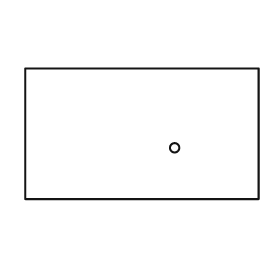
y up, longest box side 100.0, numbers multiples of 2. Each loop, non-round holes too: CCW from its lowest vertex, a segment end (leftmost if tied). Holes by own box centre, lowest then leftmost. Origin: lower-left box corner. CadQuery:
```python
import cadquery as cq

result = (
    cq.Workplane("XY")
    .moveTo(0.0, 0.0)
    .lineTo(100.0, 0.0)
    .lineTo(100.0, 56.0)
    .lineTo(0.0, 56.0)
    .close()
    .moveTo(64.0, 22.0)
    .circle(2.0)
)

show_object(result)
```